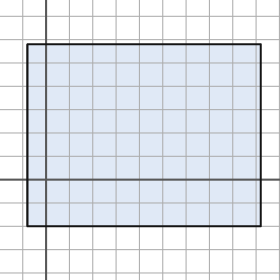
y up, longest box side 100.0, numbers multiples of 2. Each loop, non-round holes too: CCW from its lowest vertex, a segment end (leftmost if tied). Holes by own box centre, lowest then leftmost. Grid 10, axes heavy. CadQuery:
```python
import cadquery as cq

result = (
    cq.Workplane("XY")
    .moveTo(-8.0, -20.0)
    .lineTo(92.0, -20.0)
    .lineTo(92.0, 58.0)
    .lineTo(-8.0, 58.0)
    .close()
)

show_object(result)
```